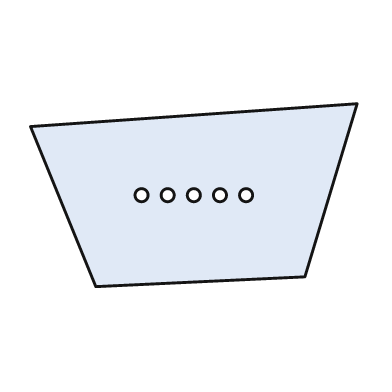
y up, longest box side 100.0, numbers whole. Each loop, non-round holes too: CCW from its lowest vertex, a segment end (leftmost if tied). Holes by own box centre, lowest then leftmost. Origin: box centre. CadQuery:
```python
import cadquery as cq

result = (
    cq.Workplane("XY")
    .moveTo(-30.0, -28.0)
    .lineTo(34.0, -25.0)
    .lineTo(50.0, 28.0)
    .lineTo(-50.0, 21.0)
    .close()
    .moveTo(-16.0, 0.0)
    .circle(2.0)
    .moveTo(-8.0, 0.0)
    .circle(2.0)
    .moveTo(0.0, 0.0)
    .circle(2.0)
    .moveTo(8.0, 0.0)
    .circle(2.0)
    .moveTo(16.0, 0.0)
    .circle(2.0)
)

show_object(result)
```